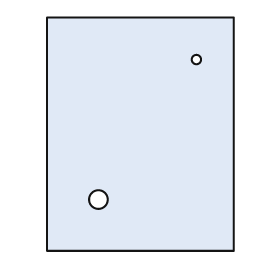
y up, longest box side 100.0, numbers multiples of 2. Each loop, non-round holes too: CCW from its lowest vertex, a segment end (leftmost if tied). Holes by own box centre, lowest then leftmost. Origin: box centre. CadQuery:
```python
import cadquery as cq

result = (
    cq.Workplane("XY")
    .moveTo(-40.0, -50.0)
    .lineTo(40.0, -50.0)
    .lineTo(40.0, 50.0)
    .lineTo(-40.0, 50.0)
    .close()
    .moveTo(-18.0, -28.0)
    .circle(4.0)
    .moveTo(24.0, 32.0)
    .circle(2.0)
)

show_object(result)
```